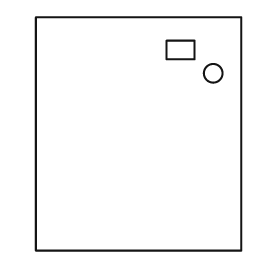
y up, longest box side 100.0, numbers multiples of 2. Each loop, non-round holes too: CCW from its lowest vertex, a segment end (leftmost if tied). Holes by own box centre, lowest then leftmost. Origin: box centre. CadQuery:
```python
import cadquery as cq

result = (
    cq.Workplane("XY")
    .moveTo(-44.0, -50.0)
    .lineTo(44.0, -50.0)
    .lineTo(44.0, 50.0)
    .lineTo(-44.0, 50.0)
    .close()
    .moveTo(32.0, 26.0)
    .circle(4.0)
    .moveTo(12.0, 32.0)
    .lineTo(24.0, 32.0)
    .lineTo(24.0, 40.0)
    .lineTo(12.0, 40.0)
    .close()
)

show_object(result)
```